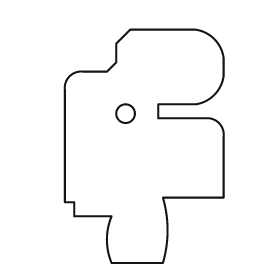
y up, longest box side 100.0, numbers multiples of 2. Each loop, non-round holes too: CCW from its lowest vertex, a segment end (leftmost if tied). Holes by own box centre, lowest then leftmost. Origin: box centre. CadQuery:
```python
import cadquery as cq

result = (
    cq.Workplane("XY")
    .moveTo(-14.0, -50.0)
    .lineTo(8.0, -50.0)
    .threePointArc((10.0, -36.0), (8.0, -22.0))
    .lineTo(34.0, -22.0)
    .lineTo(34.0, 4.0)
    .threePointArc((32.0, 10.0), (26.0, 12.0))
    .lineTo(6.0, 12.0)
    .lineTo(6.0, 18.0)
    .lineTo(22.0, 18.0)
    .threePointArc((30.0, 22.0), (34.0, 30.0))
    .lineTo(34.0, 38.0)
    .threePointArc((30.0, 46.0), (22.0, 50.0))
    .lineTo(-6.0, 50.0)
    .lineTo(-12.0, 44.0)
    .lineTo(-12.0, 36.0)
    .lineTo(-16.0, 32.0)
    .lineTo(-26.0, 32.0)
    .threePointArc((-32.0, 30.0), (-34.0, 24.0))
    .lineTo(-34.0, -24.0)
    .lineTo(-30.0, -24.0)
    .lineTo(-30.0, -30.0)
    .lineTo(-14.0, -30.0)
    .threePointArc((-16.0, -40.0), (-14.0, -50.0))
    .close()
    .moveTo(-8.0, 14.0)
    .circle(4.0)
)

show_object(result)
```